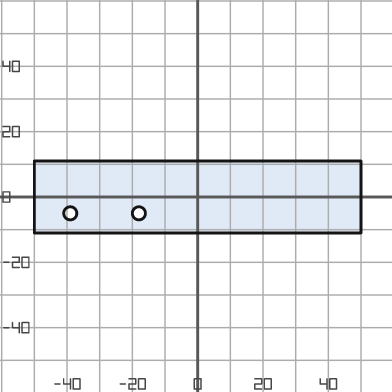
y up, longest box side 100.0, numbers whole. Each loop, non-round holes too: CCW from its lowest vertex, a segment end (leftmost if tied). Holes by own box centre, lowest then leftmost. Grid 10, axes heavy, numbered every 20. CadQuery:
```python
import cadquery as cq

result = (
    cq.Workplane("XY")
    .moveTo(-50.0, -11.0)
    .lineTo(50.0, -11.0)
    .lineTo(50.0, 11.0)
    .lineTo(-50.0, 11.0)
    .close()
    .moveTo(-39.0, -5.0)
    .circle(2.0)
    .moveTo(-18.0, -5.0)
    .circle(2.0)
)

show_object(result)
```